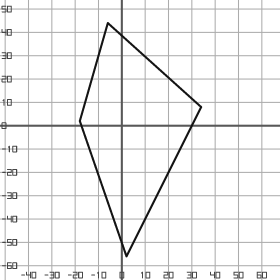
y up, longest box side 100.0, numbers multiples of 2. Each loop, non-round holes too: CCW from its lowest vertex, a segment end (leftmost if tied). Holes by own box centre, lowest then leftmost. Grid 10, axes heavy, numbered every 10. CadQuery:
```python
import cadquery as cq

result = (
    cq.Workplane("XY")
    .moveTo(2.0, -56.0)
    .lineTo(34.0, 8.0)
    .lineTo(-6.0, 44.0)
    .lineTo(-18.0, 2.0)
    .close()
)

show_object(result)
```